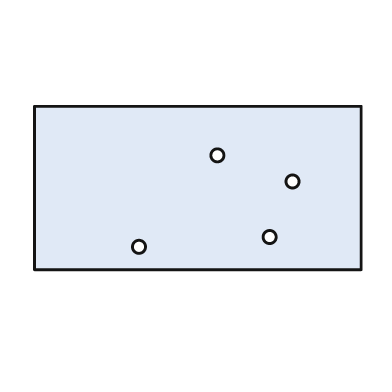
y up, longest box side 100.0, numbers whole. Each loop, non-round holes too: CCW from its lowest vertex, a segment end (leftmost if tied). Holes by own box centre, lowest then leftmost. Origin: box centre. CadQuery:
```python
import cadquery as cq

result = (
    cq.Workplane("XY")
    .moveTo(-50.0, -25.0)
    .lineTo(50.0, -25.0)
    .lineTo(50.0, 25.0)
    .lineTo(-50.0, 25.0)
    .close()
    .moveTo(-18.0, -18.0)
    .circle(2.0)
    .moveTo(22.0, -15.0)
    .circle(2.0)
    .moveTo(29.0, 2.0)
    .circle(2.0)
    .moveTo(6.0, 10.0)
    .circle(2.0)
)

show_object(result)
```